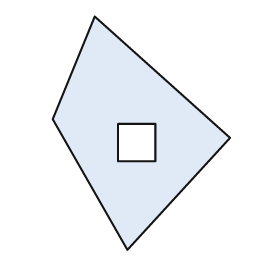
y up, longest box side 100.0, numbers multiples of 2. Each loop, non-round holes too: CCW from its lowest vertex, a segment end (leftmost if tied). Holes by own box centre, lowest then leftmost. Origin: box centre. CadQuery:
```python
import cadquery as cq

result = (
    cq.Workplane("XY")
    .moveTo(-6.0, -50.0)
    .lineTo(38.0, -2.0)
    .lineTo(-20.0, 50.0)
    .lineTo(-38.0, 6.0)
    .close()
    .moveTo(-10.0, -12.0)
    .lineTo(6.0, -12.0)
    .lineTo(6.0, 4.0)
    .lineTo(-10.0, 4.0)
    .close()
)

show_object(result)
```